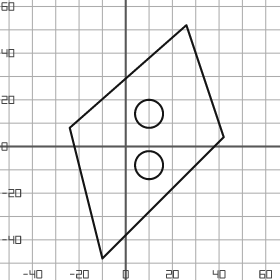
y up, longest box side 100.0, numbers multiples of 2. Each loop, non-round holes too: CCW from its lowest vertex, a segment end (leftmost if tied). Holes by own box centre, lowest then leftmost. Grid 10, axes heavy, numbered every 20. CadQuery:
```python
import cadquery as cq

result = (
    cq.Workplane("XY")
    .moveTo(-10.0, -48.0)
    .lineTo(42.0, 4.0)
    .lineTo(26.0, 52.0)
    .lineTo(-24.0, 8.0)
    .close()
    .moveTo(10.0, -8.0)
    .circle(6.0)
    .moveTo(10.0, 14.0)
    .circle(6.0)
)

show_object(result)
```